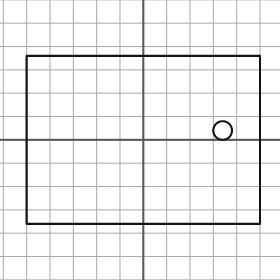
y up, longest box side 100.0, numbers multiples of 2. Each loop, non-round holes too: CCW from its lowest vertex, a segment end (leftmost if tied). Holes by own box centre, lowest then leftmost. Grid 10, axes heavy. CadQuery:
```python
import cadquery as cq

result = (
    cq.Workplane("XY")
    .moveTo(-50.0, -36.0)
    .lineTo(50.0, -36.0)
    .lineTo(50.0, 36.0)
    .lineTo(-50.0, 36.0)
    .close()
    .moveTo(34.0, 4.0)
    .circle(4.0)
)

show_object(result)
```